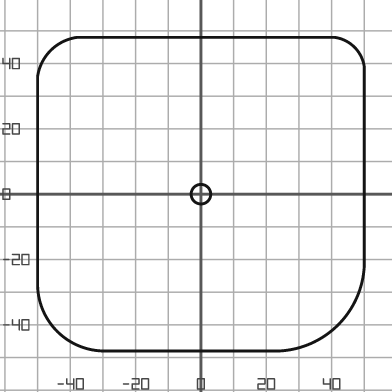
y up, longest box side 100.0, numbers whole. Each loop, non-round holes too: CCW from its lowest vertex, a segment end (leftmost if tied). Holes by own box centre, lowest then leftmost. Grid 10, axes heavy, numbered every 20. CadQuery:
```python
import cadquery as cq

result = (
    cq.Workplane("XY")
    .moveTo(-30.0, -48.0)
    .lineTo(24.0, -48.0)
    .threePointArc((42.0, -40.0), (50.0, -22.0))
    .lineTo(50.0, 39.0)
    .threePointArc((47.0, 45.0), (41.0, 48.0))
    .lineTo(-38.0, 48.0)
    .threePointArc((-46.0, 44.0), (-50.0, 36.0))
    .lineTo(-50.0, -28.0)
    .threePointArc((-44.0, -42.0), (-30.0, -48.0))
    .close()
    .moveTo(0.0, 0.0)
    .circle(3.0)
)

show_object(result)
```